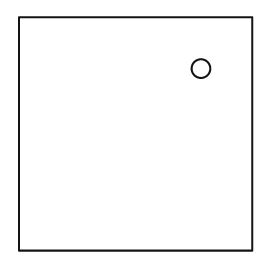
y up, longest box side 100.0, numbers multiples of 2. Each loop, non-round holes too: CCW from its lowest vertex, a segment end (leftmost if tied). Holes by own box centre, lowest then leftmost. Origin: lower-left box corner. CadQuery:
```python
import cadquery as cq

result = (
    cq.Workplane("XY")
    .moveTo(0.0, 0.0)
    .lineTo(100.0, 0.0)
    .lineTo(100.0, 100.0)
    .lineTo(0.0, 100.0)
    .close()
    .moveTo(78.0, 78.0)
    .circle(4.0)
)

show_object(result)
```